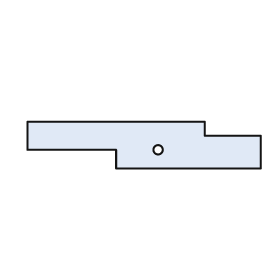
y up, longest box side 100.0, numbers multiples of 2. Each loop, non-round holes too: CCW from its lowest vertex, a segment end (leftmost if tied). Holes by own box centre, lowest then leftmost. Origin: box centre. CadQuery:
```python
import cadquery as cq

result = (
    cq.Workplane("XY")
    .moveTo(-12.0, -10.0)
    .lineTo(50.0, -10.0)
    .lineTo(50.0, 4.0)
    .lineTo(26.0, 4.0)
    .lineTo(26.0, 10.0)
    .lineTo(-50.0, 10.0)
    .lineTo(-50.0, -2.0)
    .lineTo(-12.0, -2.0)
    .close()
    .moveTo(6.0, -2.0)
    .circle(2.0)
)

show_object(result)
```